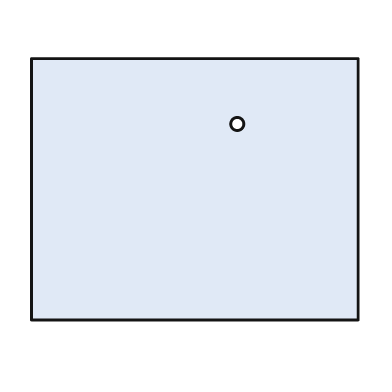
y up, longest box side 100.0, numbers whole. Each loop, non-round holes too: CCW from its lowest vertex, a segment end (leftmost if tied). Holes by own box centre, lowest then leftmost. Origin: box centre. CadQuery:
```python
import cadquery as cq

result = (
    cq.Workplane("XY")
    .moveTo(-50.0, -40.0)
    .lineTo(50.0, -40.0)
    .lineTo(50.0, 40.0)
    .lineTo(-50.0, 40.0)
    .close()
    .moveTo(13.0, 20.0)
    .circle(2.0)
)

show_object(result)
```